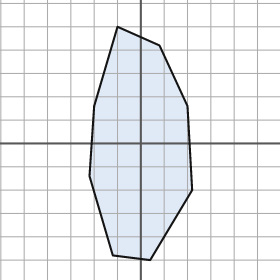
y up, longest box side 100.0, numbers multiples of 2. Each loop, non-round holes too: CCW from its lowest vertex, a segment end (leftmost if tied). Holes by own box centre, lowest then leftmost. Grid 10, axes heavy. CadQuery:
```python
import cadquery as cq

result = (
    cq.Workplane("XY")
    .moveTo(4.0, -50.0)
    .lineTo(22.0, -20.0)
    .lineTo(20.0, 16.0)
    .lineTo(8.0, 42.0)
    .lineTo(-10.0, 50.0)
    .lineTo(-20.0, 16.0)
    .lineTo(-22.0, -14.0)
    .lineTo(-12.0, -48.0)
    .close()
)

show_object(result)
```